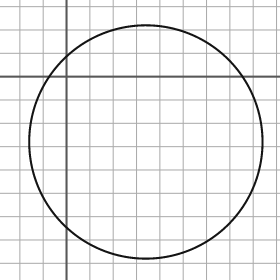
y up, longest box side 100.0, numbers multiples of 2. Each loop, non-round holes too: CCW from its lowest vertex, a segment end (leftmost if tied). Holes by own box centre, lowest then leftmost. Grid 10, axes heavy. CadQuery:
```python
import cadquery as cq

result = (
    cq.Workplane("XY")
    .moveTo(34.0, -28.0)
    .circle(50.0)
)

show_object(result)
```